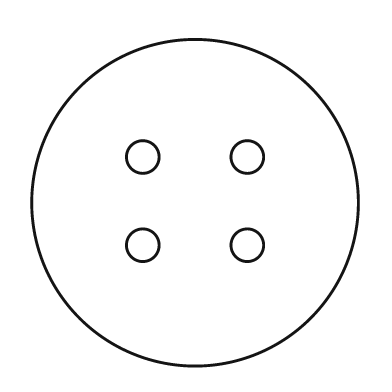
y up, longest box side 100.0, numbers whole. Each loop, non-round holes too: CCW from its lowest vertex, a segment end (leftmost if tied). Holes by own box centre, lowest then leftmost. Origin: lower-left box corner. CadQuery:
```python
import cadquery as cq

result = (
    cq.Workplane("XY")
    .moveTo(50.0, 50.0)
    .circle(50.0)
    .moveTo(34.0, 37.0)
    .circle(5.0)
    .moveTo(66.0, 37.0)
    .circle(5.0)
    .moveTo(34.0, 64.0)
    .circle(5.0)
    .moveTo(66.0, 64.0)
    .circle(5.0)
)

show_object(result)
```